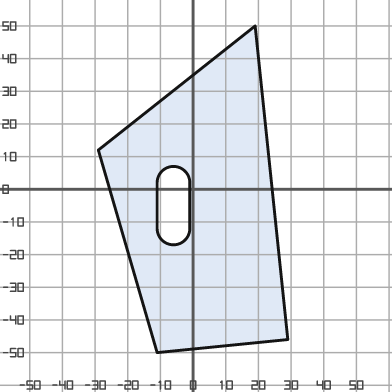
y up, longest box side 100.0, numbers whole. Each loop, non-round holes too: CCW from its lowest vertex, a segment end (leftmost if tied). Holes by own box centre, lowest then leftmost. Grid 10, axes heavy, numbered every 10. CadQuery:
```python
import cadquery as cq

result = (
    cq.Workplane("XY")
    .moveTo(-11.0, -50.0)
    .lineTo(29.0, -46.0)
    .lineTo(19.0, 50.0)
    .lineTo(-29.0, 12.0)
    .close()
    .moveTo(-11.0, -12.0)
    .threePointArc((-6.0, -17.0), (-1.0, -12.0))
    .lineTo(-1.0, 2.0)
    .threePointArc((-6.0, 7.0), (-11.0, 2.0))
    .close()
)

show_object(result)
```